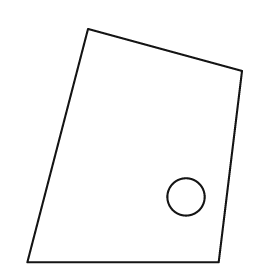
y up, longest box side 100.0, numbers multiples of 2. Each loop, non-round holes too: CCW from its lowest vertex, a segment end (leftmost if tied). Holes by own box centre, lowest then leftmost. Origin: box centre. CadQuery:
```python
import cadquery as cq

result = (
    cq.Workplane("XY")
    .moveTo(-46.0, -50.0)
    .lineTo(36.0, -50.0)
    .lineTo(46.0, 32.0)
    .lineTo(-20.0, 50.0)
    .close()
    .moveTo(22.0, -22.0)
    .circle(8.0)
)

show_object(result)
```